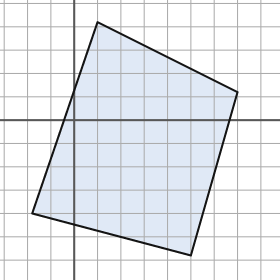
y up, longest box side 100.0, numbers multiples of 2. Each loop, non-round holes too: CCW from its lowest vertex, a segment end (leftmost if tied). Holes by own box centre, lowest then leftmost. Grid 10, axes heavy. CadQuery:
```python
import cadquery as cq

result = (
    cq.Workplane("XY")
    .moveTo(50.0, -58.0)
    .lineTo(70.0, 12.0)
    .lineTo(10.0, 42.0)
    .lineTo(-18.0, -40.0)
    .close()
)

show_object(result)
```